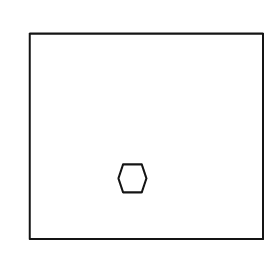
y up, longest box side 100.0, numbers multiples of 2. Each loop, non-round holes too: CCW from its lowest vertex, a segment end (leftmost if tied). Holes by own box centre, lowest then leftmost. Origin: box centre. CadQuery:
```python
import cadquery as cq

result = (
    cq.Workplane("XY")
    .moveTo(-50.0, -44.0)
    .lineTo(50.0, -44.0)
    .lineTo(50.0, 44.0)
    .lineTo(-50.0, 44.0)
    .close()
    .moveTo(-10.0, -24.0)
    .lineTo(-2.0, -24.0)
    .lineTo(0.0, -18.0)
    .lineTo(-2.0, -12.0)
    .lineTo(-10.0, -12.0)
    .lineTo(-12.0, -18.0)
    .close()
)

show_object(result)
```